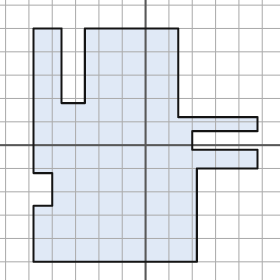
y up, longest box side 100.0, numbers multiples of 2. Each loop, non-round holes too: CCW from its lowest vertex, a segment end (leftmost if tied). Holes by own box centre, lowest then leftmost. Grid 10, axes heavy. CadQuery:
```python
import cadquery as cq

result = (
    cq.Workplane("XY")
    .moveTo(-48.0, -50.0)
    .lineTo(22.0, -50.0)
    .lineTo(22.0, -10.0)
    .lineTo(48.0, -10.0)
    .lineTo(48.0, -2.0)
    .lineTo(20.0, -2.0)
    .lineTo(20.0, 6.0)
    .lineTo(48.0, 6.0)
    .lineTo(48.0, 12.0)
    .lineTo(14.0, 12.0)
    .lineTo(14.0, 50.0)
    .lineTo(-26.0, 50.0)
    .lineTo(-26.0, 18.0)
    .lineTo(-36.0, 18.0)
    .lineTo(-36.0, 50.0)
    .lineTo(-48.0, 50.0)
    .lineTo(-48.0, -12.0)
    .lineTo(-40.0, -12.0)
    .lineTo(-40.0, -26.0)
    .lineTo(-48.0, -26.0)
    .close()
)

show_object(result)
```